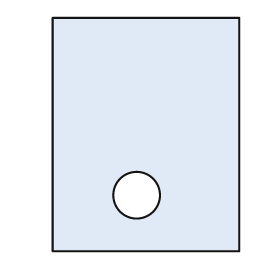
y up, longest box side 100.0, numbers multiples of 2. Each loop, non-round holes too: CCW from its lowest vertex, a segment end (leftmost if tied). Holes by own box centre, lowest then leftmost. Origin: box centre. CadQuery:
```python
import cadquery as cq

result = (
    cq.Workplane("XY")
    .moveTo(-40.0, -50.0)
    .lineTo(40.0, -50.0)
    .lineTo(40.0, 50.0)
    .lineTo(-40.0, 50.0)
    .close()
    .moveTo(-4.0, -26.0)
    .circle(10.0)
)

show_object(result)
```